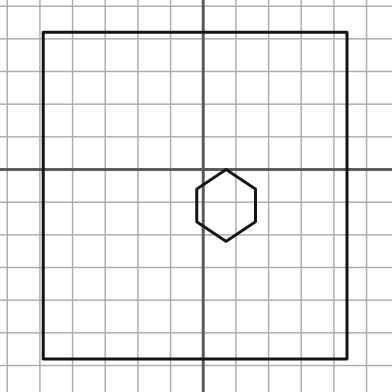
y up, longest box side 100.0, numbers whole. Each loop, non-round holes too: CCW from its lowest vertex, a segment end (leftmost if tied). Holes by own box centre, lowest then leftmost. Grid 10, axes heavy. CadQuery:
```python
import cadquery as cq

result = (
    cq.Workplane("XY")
    .moveTo(-49.0, -58.0)
    .lineTo(44.0, -58.0)
    .lineTo(44.0, 42.0)
    .lineTo(-49.0, 42.0)
    .close()
    .moveTo(7.0, -22.0)
    .lineTo(16.0, -16.0)
    .lineTo(16.0, -6.0)
    .lineTo(7.0, 0.0)
    .lineTo(-2.0, -6.0)
    .lineTo(-2.0, -16.0)
    .close()
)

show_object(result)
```